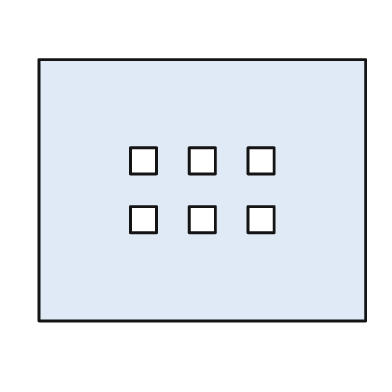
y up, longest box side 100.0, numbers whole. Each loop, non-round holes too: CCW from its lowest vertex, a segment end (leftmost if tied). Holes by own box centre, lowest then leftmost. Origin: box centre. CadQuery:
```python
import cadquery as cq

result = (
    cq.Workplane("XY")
    .moveTo(-50.0, -40.0)
    .lineTo(50.0, -40.0)
    .lineTo(50.0, 40.0)
    .lineTo(-50.0, 40.0)
    .close()
    .moveTo(-22.0, -13.0)
    .lineTo(-14.0, -13.0)
    .lineTo(-14.0, -5.0)
    .lineTo(-22.0, -5.0)
    .close()
    .moveTo(-4.0, -13.0)
    .lineTo(4.0, -13.0)
    .lineTo(4.0, -5.0)
    .lineTo(-4.0, -5.0)
    .close()
    .moveTo(14.0, -13.0)
    .lineTo(22.0, -13.0)
    .lineTo(22.0, -5.0)
    .lineTo(14.0, -5.0)
    .close()
    .moveTo(-22.0, 5.0)
    .lineTo(-14.0, 5.0)
    .lineTo(-14.0, 13.0)
    .lineTo(-22.0, 13.0)
    .close()
    .moveTo(-4.0, 5.0)
    .lineTo(4.0, 5.0)
    .lineTo(4.0, 13.0)
    .lineTo(-4.0, 13.0)
    .close()
    .moveTo(14.0, 5.0)
    .lineTo(22.0, 5.0)
    .lineTo(22.0, 13.0)
    .lineTo(14.0, 13.0)
    .close()
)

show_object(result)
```